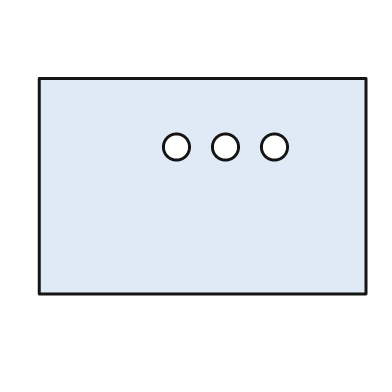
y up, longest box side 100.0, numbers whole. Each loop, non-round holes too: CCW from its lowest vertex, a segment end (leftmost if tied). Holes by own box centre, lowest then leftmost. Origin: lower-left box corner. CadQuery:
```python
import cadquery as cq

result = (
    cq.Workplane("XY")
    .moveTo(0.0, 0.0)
    .lineTo(100.0, 0.0)
    .lineTo(100.0, 66.0)
    .lineTo(0.0, 66.0)
    .close()
    .moveTo(42.0, 45.0)
    .circle(4.0)
    .moveTo(57.0, 45.0)
    .circle(4.0)
    .moveTo(72.0, 45.0)
    .circle(4.0)
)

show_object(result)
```